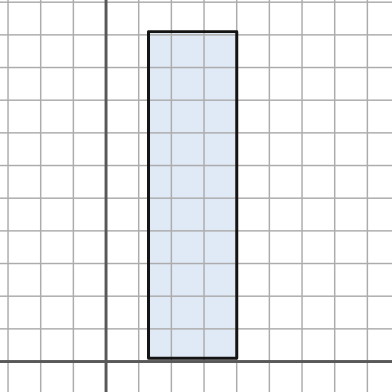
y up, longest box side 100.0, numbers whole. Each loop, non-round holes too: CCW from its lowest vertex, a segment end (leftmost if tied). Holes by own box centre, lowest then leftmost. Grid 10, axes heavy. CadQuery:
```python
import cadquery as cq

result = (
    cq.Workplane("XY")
    .moveTo(13.0, 1.0)
    .lineTo(40.0, 1.0)
    .lineTo(40.0, 101.0)
    .lineTo(13.0, 101.0)
    .close()
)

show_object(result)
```